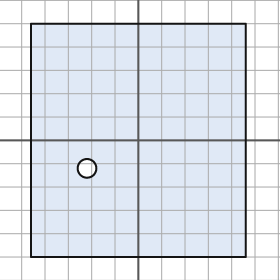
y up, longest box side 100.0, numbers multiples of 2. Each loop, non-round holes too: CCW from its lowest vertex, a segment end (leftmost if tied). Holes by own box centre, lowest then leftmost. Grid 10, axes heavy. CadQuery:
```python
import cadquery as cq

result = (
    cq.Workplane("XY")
    .moveTo(-46.0, -50.0)
    .lineTo(46.0, -50.0)
    .lineTo(46.0, 50.0)
    .lineTo(-46.0, 50.0)
    .close()
    .moveTo(-22.0, -12.0)
    .circle(4.0)
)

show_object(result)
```